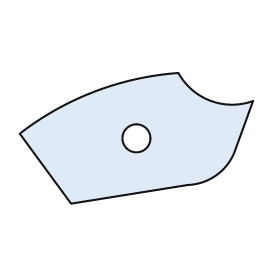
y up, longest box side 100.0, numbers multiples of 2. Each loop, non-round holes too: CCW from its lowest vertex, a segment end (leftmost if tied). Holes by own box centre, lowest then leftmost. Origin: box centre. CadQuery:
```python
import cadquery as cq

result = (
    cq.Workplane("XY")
    .moveTo(-28.0, -28.0)
    .lineTo(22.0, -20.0)
    .threePointArc((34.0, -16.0), (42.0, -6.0))
    .lineTo(50.0, 16.0)
    .threePointArc((32.0, 16.0), (18.0, 28.0))
    .threePointArc((-18.0, 20.0), (-50.0, 2.0))
    .close()
    .moveTo(0.0, 0.0)
    .circle(6.0)
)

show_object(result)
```